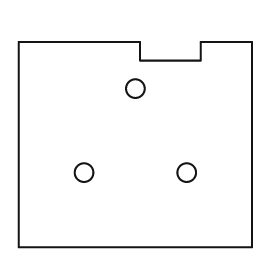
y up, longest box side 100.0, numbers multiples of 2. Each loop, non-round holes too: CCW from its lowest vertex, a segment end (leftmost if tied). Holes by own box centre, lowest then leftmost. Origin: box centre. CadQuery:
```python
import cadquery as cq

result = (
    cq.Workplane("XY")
    .moveTo(-50.0, -44.0)
    .lineTo(50.0, -44.0)
    .lineTo(50.0, 44.0)
    .lineTo(28.0, 44.0)
    .lineTo(28.0, 36.0)
    .lineTo(2.0, 36.0)
    .lineTo(2.0, 44.0)
    .lineTo(-50.0, 44.0)
    .close()
    .moveTo(-22.0, -12.0)
    .circle(4.0)
    .moveTo(22.0, -12.0)
    .circle(4.0)
    .moveTo(0.0, 24.0)
    .circle(4.0)
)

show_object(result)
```